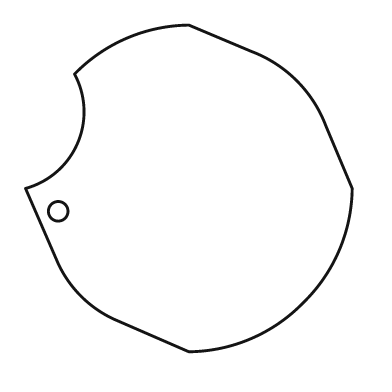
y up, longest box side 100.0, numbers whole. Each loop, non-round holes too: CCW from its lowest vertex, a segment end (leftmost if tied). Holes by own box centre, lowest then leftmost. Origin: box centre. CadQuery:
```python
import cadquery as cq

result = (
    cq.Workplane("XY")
    .moveTo(0.0, -50.0)
    .threePointArc((19.0, -46.0), (35.0, -35.0))
    .threePointArc((46.0, -19.0), (50.0, 0.0))
    .lineTo(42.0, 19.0)
    .threePointArc((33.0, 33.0), (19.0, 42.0))
    .lineTo(0.0, 50.0)
    .threePointArc((-19.0, 46.0), (-35.0, 35.0))
    .threePointArc((-34.0, 14.0), (-50.0, 0.0))
    .lineTo(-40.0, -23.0)
    .threePointArc((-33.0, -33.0), (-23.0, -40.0))
    .close()
    .moveTo(-40.0, -7.0)
    .circle(3.0)
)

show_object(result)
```